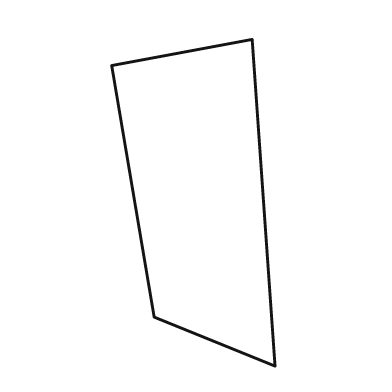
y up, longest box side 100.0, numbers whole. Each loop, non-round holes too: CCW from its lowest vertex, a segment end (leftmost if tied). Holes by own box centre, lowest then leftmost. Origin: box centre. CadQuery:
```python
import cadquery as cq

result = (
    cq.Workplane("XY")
    .moveTo(25.0, -50.0)
    .lineTo(18.0, 50.0)
    .lineTo(-25.0, 42.0)
    .lineTo(-12.0, -35.0)
    .close()
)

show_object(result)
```